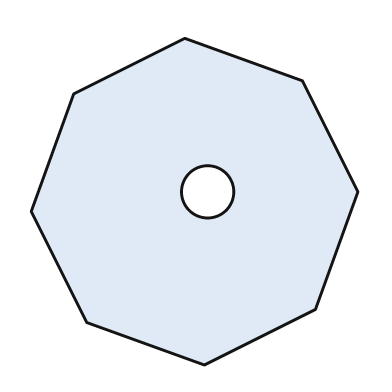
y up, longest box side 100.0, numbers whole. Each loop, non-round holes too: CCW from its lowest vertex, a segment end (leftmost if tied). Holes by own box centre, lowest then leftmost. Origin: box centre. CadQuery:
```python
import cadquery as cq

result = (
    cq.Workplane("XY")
    .moveTo(3.0, -50.0)
    .lineTo(37.0, -33.0)
    .lineTo(50.0, 3.0)
    .lineTo(33.0, 37.0)
    .lineTo(-3.0, 50.0)
    .lineTo(-37.0, 33.0)
    .lineTo(-50.0, -3.0)
    .lineTo(-33.0, -37.0)
    .close()
    .moveTo(4.0, 3.0)
    .circle(8.0)
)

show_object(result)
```